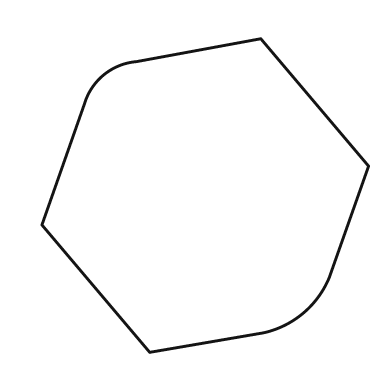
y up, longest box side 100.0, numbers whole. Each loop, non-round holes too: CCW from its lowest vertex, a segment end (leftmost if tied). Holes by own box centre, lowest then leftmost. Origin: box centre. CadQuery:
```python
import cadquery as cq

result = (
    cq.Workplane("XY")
    .moveTo(-17.0, -48.0)
    .lineTo(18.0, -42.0)
    .threePointArc((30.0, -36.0), (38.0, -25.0))
    .lineTo(50.0, 9.0)
    .lineTo(17.0, 48.0)
    .lineTo(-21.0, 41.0)
    .threePointArc((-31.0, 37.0), (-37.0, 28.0))
    .lineTo(-50.0, -9.0)
    .close()
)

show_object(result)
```